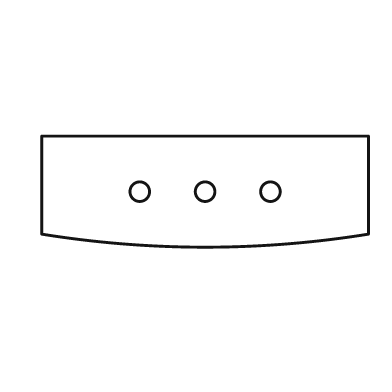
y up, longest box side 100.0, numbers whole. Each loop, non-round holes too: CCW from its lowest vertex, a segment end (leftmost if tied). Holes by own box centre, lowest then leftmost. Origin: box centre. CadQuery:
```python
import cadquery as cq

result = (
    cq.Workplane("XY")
    .moveTo(-50.0, -13.0)
    .threePointArc((0.0, -17.0), (50.0, -13.0))
    .lineTo(50.0, 17.0)
    .lineTo(-50.0, 17.0)
    .close()
    .moveTo(-20.0, 0.0)
    .circle(3.0)
    .moveTo(0.0, 0.0)
    .circle(3.0)
    .moveTo(20.0, 0.0)
    .circle(3.0)
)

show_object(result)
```